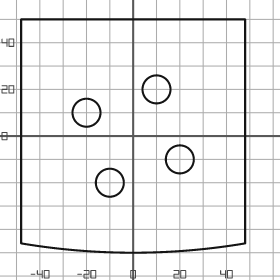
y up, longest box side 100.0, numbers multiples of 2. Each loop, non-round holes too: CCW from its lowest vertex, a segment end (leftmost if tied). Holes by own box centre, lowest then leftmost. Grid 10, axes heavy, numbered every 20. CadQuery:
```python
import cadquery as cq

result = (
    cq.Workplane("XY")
    .moveTo(-48.0, -46.0)
    .threePointArc((0.0, -50.0), (48.0, -46.0))
    .lineTo(48.0, 50.0)
    .lineTo(-48.0, 50.0)
    .close()
    .moveTo(-10.0, -20.0)
    .circle(6.0)
    .moveTo(20.0, -10.0)
    .circle(6.0)
    .moveTo(-20.0, 10.0)
    .circle(6.0)
    .moveTo(10.0, 20.0)
    .circle(6.0)
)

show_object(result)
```